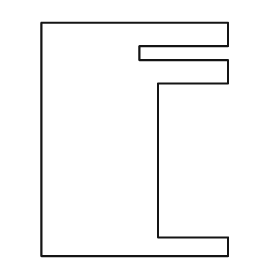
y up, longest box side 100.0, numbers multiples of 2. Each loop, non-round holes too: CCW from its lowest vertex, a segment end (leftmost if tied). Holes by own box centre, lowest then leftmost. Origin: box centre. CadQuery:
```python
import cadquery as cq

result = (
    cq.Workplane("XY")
    .moveTo(-40.0, -50.0)
    .lineTo(40.0, -50.0)
    .lineTo(40.0, -42.0)
    .lineTo(10.0, -42.0)
    .lineTo(10.0, 24.0)
    .lineTo(40.0, 24.0)
    .lineTo(40.0, 34.0)
    .lineTo(2.0, 34.0)
    .lineTo(2.0, 40.0)
    .lineTo(40.0, 40.0)
    .lineTo(40.0, 50.0)
    .lineTo(-40.0, 50.0)
    .close()
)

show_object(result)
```